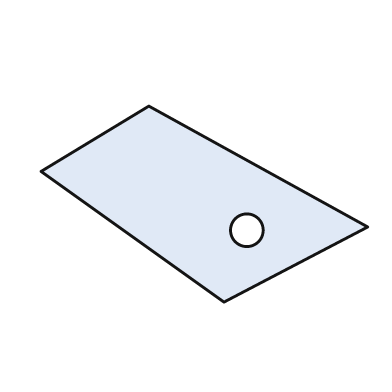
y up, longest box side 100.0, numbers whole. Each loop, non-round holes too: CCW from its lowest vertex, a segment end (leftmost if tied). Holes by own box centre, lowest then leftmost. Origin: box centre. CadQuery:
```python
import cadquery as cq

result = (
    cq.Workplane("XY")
    .moveTo(6.0, -30.0)
    .lineTo(50.0, -7.0)
    .lineTo(-17.0, 30.0)
    .lineTo(-50.0, 10.0)
    .close()
    .moveTo(13.0, -8.0)
    .circle(5.0)
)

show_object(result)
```